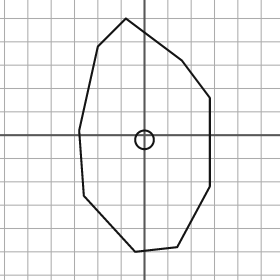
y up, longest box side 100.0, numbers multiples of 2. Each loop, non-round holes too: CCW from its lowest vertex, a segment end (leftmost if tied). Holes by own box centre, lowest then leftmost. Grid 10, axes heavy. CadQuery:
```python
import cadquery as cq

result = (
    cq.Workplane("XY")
    .moveTo(-4.0, -50.0)
    .lineTo(14.0, -48.0)
    .lineTo(28.0, -22.0)
    .lineTo(28.0, 16.0)
    .lineTo(16.0, 32.0)
    .lineTo(-8.0, 50.0)
    .lineTo(-20.0, 38.0)
    .lineTo(-28.0, 2.0)
    .lineTo(-26.0, -26.0)
    .close()
    .moveTo(0.0, -2.0)
    .circle(4.0)
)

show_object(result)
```